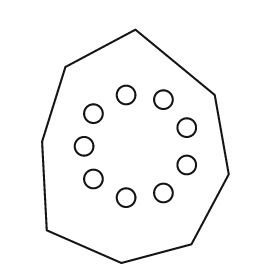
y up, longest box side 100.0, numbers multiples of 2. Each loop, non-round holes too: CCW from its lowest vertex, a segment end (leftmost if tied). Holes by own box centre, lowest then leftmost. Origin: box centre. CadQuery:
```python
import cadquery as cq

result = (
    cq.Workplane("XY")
    .moveTo(-6.0, -50.0)
    .lineTo(24.0, -42.0)
    .lineTo(40.0, -12.0)
    .lineTo(34.0, 22.0)
    .lineTo(0.0, 50.0)
    .lineTo(-30.0, 34.0)
    .lineTo(-40.0, 2.0)
    .lineTo(-38.0, -36.0)
    .close()
    .moveTo(-4.0, -22.0)
    .circle(4.0)
    .moveTo(12.0, -20.0)
    .circle(4.0)
    .moveTo(-18.0, -14.0)
    .circle(4.0)
    .moveTo(22.0, -8.0)
    .circle(4.0)
    .moveTo(-22.0, 0.0)
    .circle(4.0)
    .moveTo(22.0, 8.0)
    .circle(4.0)
    .moveTo(-18.0, 14.0)
    .circle(4.0)
    .moveTo(12.0, 20.0)
    .circle(4.0)
    .moveTo(-4.0, 22.0)
    .circle(4.0)
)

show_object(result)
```